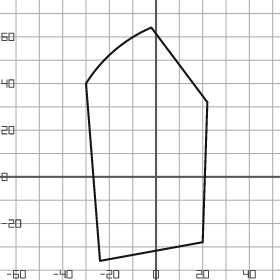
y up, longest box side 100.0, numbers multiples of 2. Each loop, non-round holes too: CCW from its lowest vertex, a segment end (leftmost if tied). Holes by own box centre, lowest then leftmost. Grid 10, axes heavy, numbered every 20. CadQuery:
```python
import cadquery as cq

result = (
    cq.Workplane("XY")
    .moveTo(-24.0, -36.0)
    .lineTo(20.0, -28.0)
    .lineTo(22.0, 32.0)
    .lineTo(-2.0, 64.0)
    .threePointArc((-18.0, 54.0), (-30.0, 40.0))
    .close()
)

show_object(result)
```